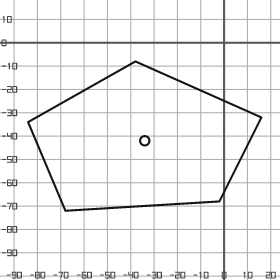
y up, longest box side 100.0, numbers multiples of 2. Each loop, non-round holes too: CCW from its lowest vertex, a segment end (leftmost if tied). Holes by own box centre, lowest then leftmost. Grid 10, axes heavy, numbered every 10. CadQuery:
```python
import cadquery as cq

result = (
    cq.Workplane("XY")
    .moveTo(-68.0, -72.0)
    .lineTo(-2.0, -68.0)
    .lineTo(16.0, -32.0)
    .lineTo(-38.0, -8.0)
    .lineTo(-84.0, -34.0)
    .close()
    .moveTo(-34.0, -42.0)
    .circle(2.0)
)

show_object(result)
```